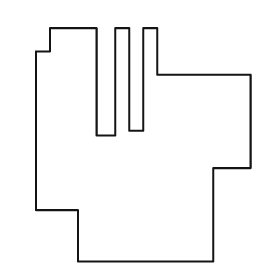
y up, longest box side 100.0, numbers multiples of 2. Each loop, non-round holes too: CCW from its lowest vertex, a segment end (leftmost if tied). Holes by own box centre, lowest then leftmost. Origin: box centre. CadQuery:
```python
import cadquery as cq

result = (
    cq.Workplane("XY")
    .moveTo(-28.0, -50.0)
    .lineTo(30.0, -50.0)
    .lineTo(30.0, -10.0)
    .lineTo(46.0, -10.0)
    .lineTo(46.0, 30.0)
    .lineTo(6.0, 30.0)
    .lineTo(6.0, 50.0)
    .lineTo(0.0, 50.0)
    .lineTo(0.0, 6.0)
    .lineTo(-6.0, 6.0)
    .lineTo(-6.0, 50.0)
    .lineTo(-12.0, 50.0)
    .lineTo(-12.0, 4.0)
    .lineTo(-20.0, 4.0)
    .lineTo(-20.0, 50.0)
    .lineTo(-40.0, 50.0)
    .lineTo(-40.0, 40.0)
    .lineTo(-46.0, 40.0)
    .lineTo(-46.0, -28.0)
    .lineTo(-28.0, -28.0)
    .close()
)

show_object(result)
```